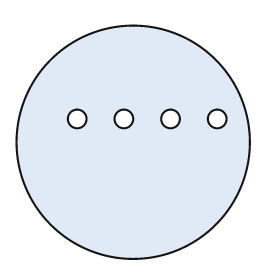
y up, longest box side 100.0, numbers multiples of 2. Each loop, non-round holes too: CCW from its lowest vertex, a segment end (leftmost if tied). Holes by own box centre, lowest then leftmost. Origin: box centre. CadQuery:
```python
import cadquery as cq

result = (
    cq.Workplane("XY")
    .moveTo(0.0, 0.0)
    .circle(50.0)
    .moveTo(-24.0, 10.0)
    .circle(4.0)
    .moveTo(-4.0, 10.0)
    .circle(4.0)
    .moveTo(16.0, 10.0)
    .circle(4.0)
    .moveTo(36.0, 10.0)
    .circle(4.0)
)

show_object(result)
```